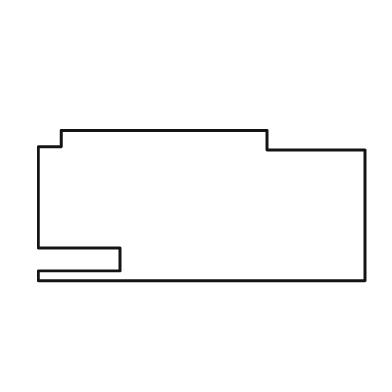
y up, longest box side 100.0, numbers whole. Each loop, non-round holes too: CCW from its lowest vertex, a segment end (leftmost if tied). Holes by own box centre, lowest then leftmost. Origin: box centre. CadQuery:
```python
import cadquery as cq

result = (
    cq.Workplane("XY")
    .moveTo(-50.0, -23.0)
    .lineTo(50.0, -23.0)
    .lineTo(50.0, 17.0)
    .lineTo(20.0, 17.0)
    .lineTo(20.0, 23.0)
    .lineTo(-43.0, 23.0)
    .lineTo(-43.0, 18.0)
    .lineTo(-50.0, 18.0)
    .lineTo(-50.0, -13.0)
    .lineTo(-25.0, -13.0)
    .lineTo(-25.0, -20.0)
    .lineTo(-50.0, -20.0)
    .close()
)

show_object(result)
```